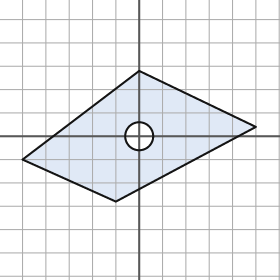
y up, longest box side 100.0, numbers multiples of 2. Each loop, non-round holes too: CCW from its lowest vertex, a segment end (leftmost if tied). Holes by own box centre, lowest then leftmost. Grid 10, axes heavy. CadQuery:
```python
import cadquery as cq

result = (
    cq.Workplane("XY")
    .moveTo(-10.0, -28.0)
    .lineTo(50.0, 4.0)
    .lineTo(0.0, 28.0)
    .lineTo(-50.0, -10.0)
    .close()
    .moveTo(0.0, 0.0)
    .circle(6.0)
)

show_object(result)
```